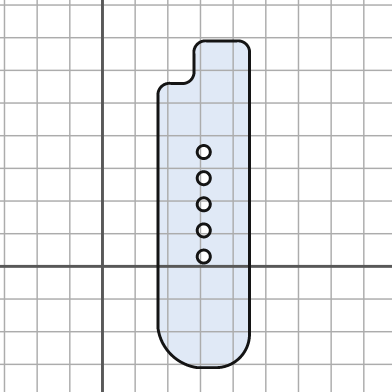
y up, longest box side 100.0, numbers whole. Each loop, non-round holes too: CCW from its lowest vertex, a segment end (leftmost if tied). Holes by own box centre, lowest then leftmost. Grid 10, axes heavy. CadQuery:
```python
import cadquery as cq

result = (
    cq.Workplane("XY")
    .moveTo(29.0, -31.0)
    .lineTo(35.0, -31.0)
    .threePointArc((42.0, -28.0), (45.0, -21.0))
    .lineTo(45.0, 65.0)
    .threePointArc((44.0, 68.0), (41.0, 69.0))
    .lineTo(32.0, 69.0)
    .threePointArc((29.0, 68.0), (28.0, 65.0))
    .lineTo(28.0, 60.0)
    .threePointArc((27.0, 57.0), (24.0, 56.0))
    .lineTo(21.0, 56.0)
    .threePointArc((18.0, 55.0), (17.0, 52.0))
    .lineTo(17.0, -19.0)
    .threePointArc((21.0, -27.0), (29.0, -31.0))
    .close()
    .moveTo(31.0, 3.0)
    .circle(2.0)
    .moveTo(31.0, 11.0)
    .circle(2.0)
    .moveTo(31.0, 19.0)
    .circle(2.0)
    .moveTo(31.0, 27.0)
    .circle(2.0)
    .moveTo(31.0, 35.0)
    .circle(2.0)
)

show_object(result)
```